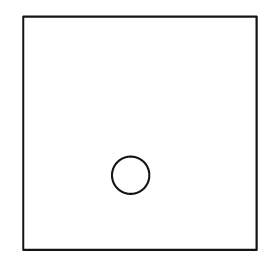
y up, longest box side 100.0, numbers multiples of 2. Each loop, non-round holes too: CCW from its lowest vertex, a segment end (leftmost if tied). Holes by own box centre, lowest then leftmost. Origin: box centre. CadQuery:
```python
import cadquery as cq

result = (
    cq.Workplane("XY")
    .moveTo(-50.0, -50.0)
    .lineTo(50.0, -50.0)
    .lineTo(50.0, 50.0)
    .lineTo(-50.0, 50.0)
    .close()
    .moveTo(-4.0, -18.0)
    .circle(8.0)
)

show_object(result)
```